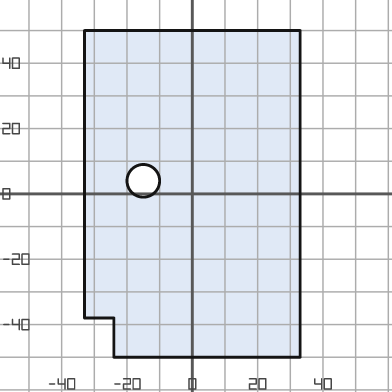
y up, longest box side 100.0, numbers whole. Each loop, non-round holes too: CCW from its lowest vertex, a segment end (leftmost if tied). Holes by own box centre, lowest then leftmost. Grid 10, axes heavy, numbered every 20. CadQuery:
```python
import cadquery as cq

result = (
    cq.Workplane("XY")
    .moveTo(-24.0, -50.0)
    .lineTo(33.0, -50.0)
    .lineTo(33.0, 50.0)
    .lineTo(-33.0, 50.0)
    .lineTo(-33.0, -38.0)
    .lineTo(-24.0, -38.0)
    .close()
    .moveTo(-15.0, 4.0)
    .circle(5.0)
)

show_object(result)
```